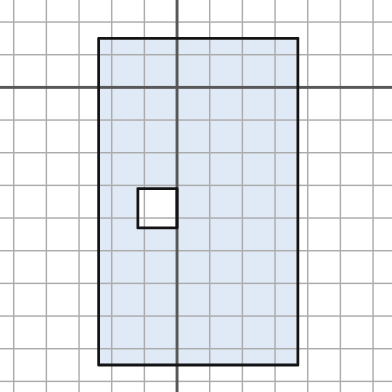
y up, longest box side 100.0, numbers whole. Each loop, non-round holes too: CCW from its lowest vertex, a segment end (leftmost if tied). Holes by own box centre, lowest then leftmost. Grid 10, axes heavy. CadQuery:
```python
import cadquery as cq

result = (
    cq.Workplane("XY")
    .moveTo(-24.0, -85.0)
    .lineTo(37.0, -85.0)
    .lineTo(37.0, 15.0)
    .lineTo(-24.0, 15.0)
    .close()
    .moveTo(-12.0, -43.0)
    .lineTo(0.0, -43.0)
    .lineTo(0.0, -31.0)
    .lineTo(-12.0, -31.0)
    .close()
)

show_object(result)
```